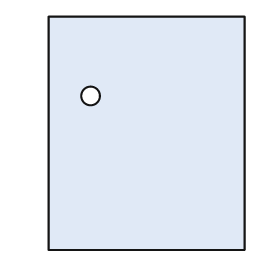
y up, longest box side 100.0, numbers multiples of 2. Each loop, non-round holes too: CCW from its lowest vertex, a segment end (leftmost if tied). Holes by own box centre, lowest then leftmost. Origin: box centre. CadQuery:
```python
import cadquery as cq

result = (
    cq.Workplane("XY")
    .moveTo(-42.0, -50.0)
    .lineTo(42.0, -50.0)
    .lineTo(42.0, 50.0)
    .lineTo(-42.0, 50.0)
    .close()
    .moveTo(-24.0, 16.0)
    .circle(4.0)
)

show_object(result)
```